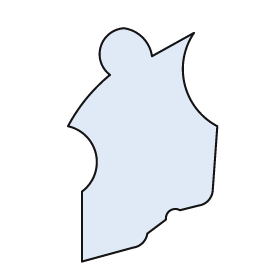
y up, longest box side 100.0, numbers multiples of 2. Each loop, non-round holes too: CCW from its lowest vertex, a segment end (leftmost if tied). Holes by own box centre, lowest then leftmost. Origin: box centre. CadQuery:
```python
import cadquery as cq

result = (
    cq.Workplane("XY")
    .moveTo(-26.0, -50.0)
    .lineTo(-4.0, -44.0)
    .threePointArc((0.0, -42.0), (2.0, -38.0))
    .lineTo(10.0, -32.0)
    .threePointArc((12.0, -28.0), (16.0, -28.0))
    .lineTo(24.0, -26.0)
    .threePointArc((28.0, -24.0), (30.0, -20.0))
    .lineTo(32.0, 8.0)
    .threePointArc((18.0, 26.0), (22.0, 48.0))
    .lineTo(4.0, 38.0)
    .threePointArc((0.0, 46.0), (-8.0, 50.0))
    .threePointArc((-18.0, 42.0), (-14.0, 30.0))
    .threePointArc((-24.0, 20.0), (-32.0, 8.0))
    .threePointArc((-20.0, -4.0), (-26.0, -20.0))
    .close()
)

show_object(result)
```